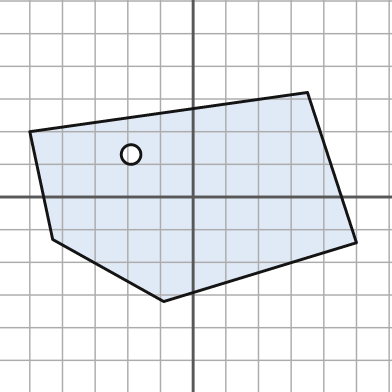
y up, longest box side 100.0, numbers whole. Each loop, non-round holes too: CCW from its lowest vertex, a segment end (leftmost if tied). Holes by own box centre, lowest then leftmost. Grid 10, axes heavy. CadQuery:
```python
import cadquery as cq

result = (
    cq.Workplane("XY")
    .moveTo(-9.0, -32.0)
    .lineTo(50.0, -14.0)
    .lineTo(35.0, 32.0)
    .lineTo(-50.0, 20.0)
    .lineTo(-43.0, -13.0)
    .close()
    .moveTo(-19.0, 13.0)
    .circle(3.0)
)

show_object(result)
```